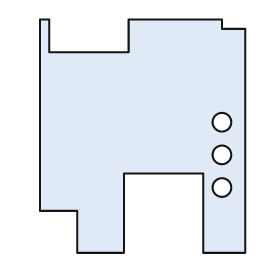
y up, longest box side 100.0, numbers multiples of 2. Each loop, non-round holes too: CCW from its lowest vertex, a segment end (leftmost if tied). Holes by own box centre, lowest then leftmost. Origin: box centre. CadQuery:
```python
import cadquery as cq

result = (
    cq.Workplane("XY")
    .moveTo(-28.0, -50.0)
    .lineTo(-8.0, -50.0)
    .lineTo(-8.0, -16.0)
    .lineTo(26.0, -16.0)
    .lineTo(26.0, -50.0)
    .lineTo(44.0, -50.0)
    .lineTo(44.0, 46.0)
    .lineTo(34.0, 46.0)
    .lineTo(34.0, 50.0)
    .lineTo(-6.0, 50.0)
    .lineTo(-6.0, 36.0)
    .lineTo(-40.0, 36.0)
    .lineTo(-40.0, 50.0)
    .lineTo(-44.0, 50.0)
    .lineTo(-44.0, -32.0)
    .lineTo(-28.0, -32.0)
    .close()
    .moveTo(34.0, -22.0)
    .circle(4.0)
    .moveTo(34.0, -8.0)
    .circle(4.0)
    .moveTo(34.0, 6.0)
    .circle(4.0)
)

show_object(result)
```